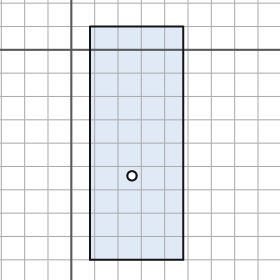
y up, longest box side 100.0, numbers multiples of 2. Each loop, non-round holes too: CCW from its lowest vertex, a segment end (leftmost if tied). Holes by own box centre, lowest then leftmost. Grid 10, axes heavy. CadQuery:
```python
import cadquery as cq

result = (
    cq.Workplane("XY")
    .moveTo(8.0, -90.0)
    .lineTo(48.0, -90.0)
    .lineTo(48.0, 10.0)
    .lineTo(8.0, 10.0)
    .close()
    .moveTo(26.0, -54.0)
    .circle(2.0)
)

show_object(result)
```